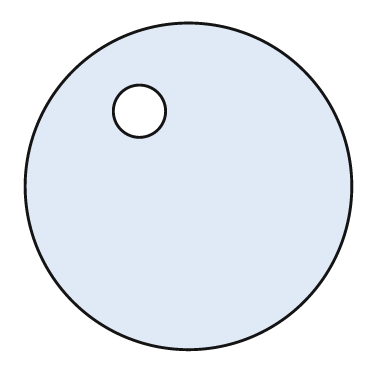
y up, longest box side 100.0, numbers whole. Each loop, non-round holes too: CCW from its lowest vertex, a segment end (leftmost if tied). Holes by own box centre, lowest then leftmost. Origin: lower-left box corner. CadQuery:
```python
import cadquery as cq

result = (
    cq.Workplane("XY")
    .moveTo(50.0, 50.0)
    .circle(50.0)
    .moveTo(35.0, 73.0)
    .circle(8.0)
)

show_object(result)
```